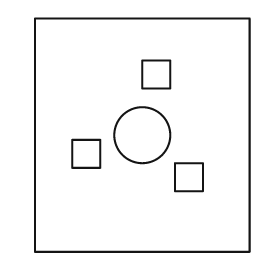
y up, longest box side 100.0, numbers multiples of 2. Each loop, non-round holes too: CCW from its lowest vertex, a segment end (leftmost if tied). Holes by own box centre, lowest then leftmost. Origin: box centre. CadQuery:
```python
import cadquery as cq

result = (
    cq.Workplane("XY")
    .moveTo(-46.0, -50.0)
    .lineTo(46.0, -50.0)
    .lineTo(46.0, 50.0)
    .lineTo(-46.0, 50.0)
    .close()
    .moveTo(14.0, -24.0)
    .lineTo(26.0, -24.0)
    .lineTo(26.0, -12.0)
    .lineTo(14.0, -12.0)
    .close()
    .moveTo(-30.0, -14.0)
    .lineTo(-18.0, -14.0)
    .lineTo(-18.0, -2.0)
    .lineTo(-30.0, -2.0)
    .close()
    .moveTo(0.0, 0.0)
    .circle(12.0)
    .moveTo(0.0, 20.0)
    .lineTo(12.0, 20.0)
    .lineTo(12.0, 32.0)
    .lineTo(0.0, 32.0)
    .close()
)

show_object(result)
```